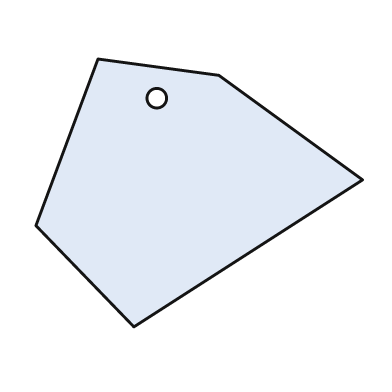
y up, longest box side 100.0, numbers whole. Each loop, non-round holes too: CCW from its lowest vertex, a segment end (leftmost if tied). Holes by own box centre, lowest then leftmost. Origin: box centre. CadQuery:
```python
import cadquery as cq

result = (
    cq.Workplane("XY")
    .moveTo(-20.0, -41.0)
    .lineTo(50.0, 4.0)
    .lineTo(6.0, 36.0)
    .lineTo(-31.0, 41.0)
    .lineTo(-50.0, -10.0)
    .close()
    .moveTo(-13.0, 29.0)
    .circle(3.0)
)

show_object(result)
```